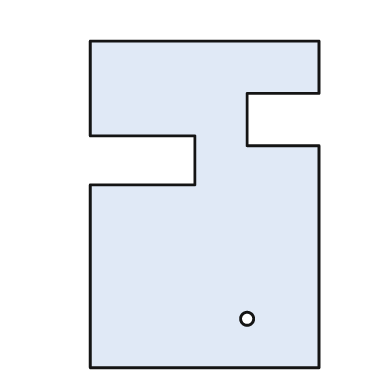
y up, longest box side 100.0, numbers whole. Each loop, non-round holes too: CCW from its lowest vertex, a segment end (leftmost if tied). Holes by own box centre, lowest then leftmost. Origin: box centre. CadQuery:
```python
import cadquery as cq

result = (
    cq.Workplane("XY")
    .moveTo(-35.0, -50.0)
    .lineTo(35.0, -50.0)
    .lineTo(35.0, 18.0)
    .lineTo(13.0, 18.0)
    .lineTo(13.0, 34.0)
    .lineTo(35.0, 34.0)
    .lineTo(35.0, 50.0)
    .lineTo(-35.0, 50.0)
    .lineTo(-35.0, 21.0)
    .lineTo(-3.0, 21.0)
    .lineTo(-3.0, 6.0)
    .lineTo(-35.0, 6.0)
    .close()
    .moveTo(13.0, -35.0)
    .circle(2.0)
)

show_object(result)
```